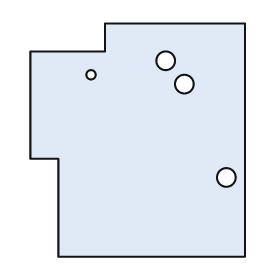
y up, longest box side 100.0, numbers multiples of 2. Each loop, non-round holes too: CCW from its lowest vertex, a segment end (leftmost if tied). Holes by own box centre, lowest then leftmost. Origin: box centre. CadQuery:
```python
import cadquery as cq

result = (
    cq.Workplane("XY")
    .moveTo(-34.0, -50.0)
    .lineTo(46.0, -50.0)
    .lineTo(46.0, 50.0)
    .lineTo(-14.0, 50.0)
    .lineTo(-14.0, 38.0)
    .lineTo(-46.0, 38.0)
    .lineTo(-46.0, -8.0)
    .lineTo(-34.0, -8.0)
    .close()
    .moveTo(38.0, -16.0)
    .circle(4.0)
    .moveTo(20.0, 24.0)
    .circle(4.0)
    .moveTo(-20.0, 28.0)
    .circle(2.0)
    .moveTo(12.0, 34.0)
    .circle(4.0)
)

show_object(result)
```